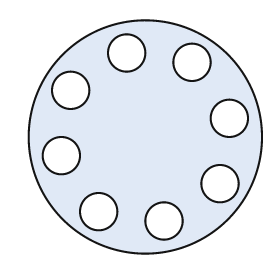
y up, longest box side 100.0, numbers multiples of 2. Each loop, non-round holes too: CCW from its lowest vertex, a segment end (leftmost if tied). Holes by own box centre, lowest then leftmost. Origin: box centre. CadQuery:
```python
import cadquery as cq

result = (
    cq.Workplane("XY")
    .moveTo(0.0, 0.0)
    .circle(50.0)
    .moveTo(8.0, -36.0)
    .circle(8.0)
    .moveTo(-20.0, -32.0)
    .circle(8.0)
    .moveTo(32.0, -20.0)
    .circle(8.0)
    .moveTo(-36.0, -8.0)
    .circle(8.0)
    .moveTo(36.0, 8.0)
    .circle(8.0)
    .moveTo(-32.0, 20.0)
    .circle(8.0)
    .moveTo(20.0, 32.0)
    .circle(8.0)
    .moveTo(-8.0, 36.0)
    .circle(8.0)
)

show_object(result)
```